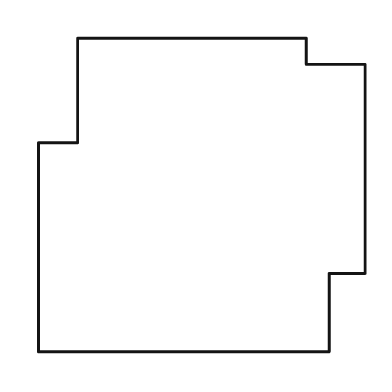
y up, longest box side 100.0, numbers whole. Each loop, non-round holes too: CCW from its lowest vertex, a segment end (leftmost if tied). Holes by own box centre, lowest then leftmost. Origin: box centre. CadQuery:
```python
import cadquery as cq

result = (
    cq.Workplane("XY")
    .moveTo(-50.0, -48.0)
    .lineTo(39.0, -48.0)
    .lineTo(39.0, -24.0)
    .lineTo(50.0, -24.0)
    .lineTo(50.0, 40.0)
    .lineTo(32.0, 40.0)
    .lineTo(32.0, 48.0)
    .lineTo(-38.0, 48.0)
    .lineTo(-38.0, 16.0)
    .lineTo(-50.0, 16.0)
    .close()
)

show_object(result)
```